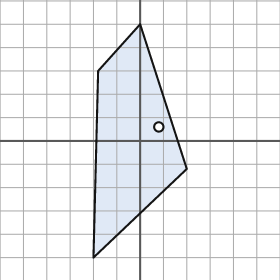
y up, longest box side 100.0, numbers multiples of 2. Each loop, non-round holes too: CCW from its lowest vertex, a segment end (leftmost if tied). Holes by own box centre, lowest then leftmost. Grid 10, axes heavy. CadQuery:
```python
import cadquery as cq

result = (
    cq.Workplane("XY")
    .moveTo(-20.0, -50.0)
    .lineTo(20.0, -12.0)
    .lineTo(0.0, 50.0)
    .lineTo(-18.0, 30.0)
    .close()
    .moveTo(8.0, 6.0)
    .circle(2.0)
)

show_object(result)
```